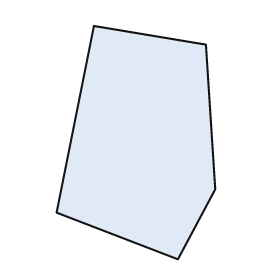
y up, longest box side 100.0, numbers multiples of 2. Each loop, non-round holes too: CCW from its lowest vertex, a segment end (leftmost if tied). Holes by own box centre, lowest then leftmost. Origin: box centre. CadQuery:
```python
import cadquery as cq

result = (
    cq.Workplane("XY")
    .moveTo(18.0, -50.0)
    .lineTo(34.0, -20.0)
    .lineTo(30.0, 42.0)
    .lineTo(-18.0, 50.0)
    .lineTo(-34.0, -30.0)
    .close()
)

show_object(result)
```